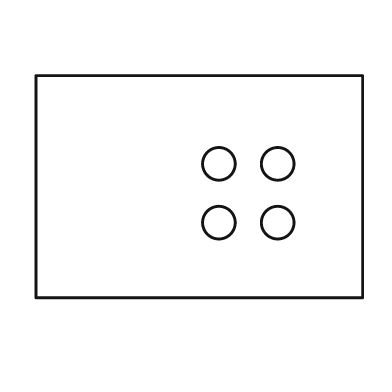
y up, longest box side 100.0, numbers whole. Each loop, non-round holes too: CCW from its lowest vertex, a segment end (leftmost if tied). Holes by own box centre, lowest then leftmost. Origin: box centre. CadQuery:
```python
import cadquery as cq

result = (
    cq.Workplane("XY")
    .moveTo(-50.0, -34.0)
    .lineTo(50.0, -34.0)
    .lineTo(50.0, 34.0)
    .lineTo(-50.0, 34.0)
    .close()
    .moveTo(6.0, -11.0)
    .circle(5.0)
    .moveTo(24.0, -11.0)
    .circle(5.0)
    .moveTo(6.0, 7.0)
    .circle(5.0)
    .moveTo(24.0, 7.0)
    .circle(5.0)
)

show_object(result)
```